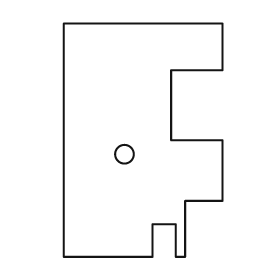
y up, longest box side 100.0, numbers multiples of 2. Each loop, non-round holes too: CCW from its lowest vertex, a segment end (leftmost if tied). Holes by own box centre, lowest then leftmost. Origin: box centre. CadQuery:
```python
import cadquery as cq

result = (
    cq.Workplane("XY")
    .moveTo(-34.0, -50.0)
    .lineTo(4.0, -50.0)
    .lineTo(4.0, -36.0)
    .lineTo(14.0, -36.0)
    .lineTo(14.0, -50.0)
    .lineTo(18.0, -50.0)
    .lineTo(18.0, -26.0)
    .lineTo(34.0, -26.0)
    .lineTo(34.0, 0.0)
    .lineTo(12.0, 0.0)
    .lineTo(12.0, 30.0)
    .lineTo(34.0, 30.0)
    .lineTo(34.0, 50.0)
    .lineTo(-34.0, 50.0)
    .close()
    .moveTo(-8.0, -6.0)
    .circle(4.0)
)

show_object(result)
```